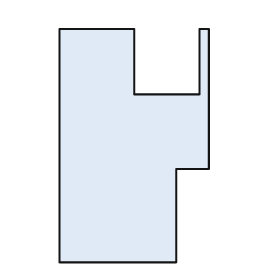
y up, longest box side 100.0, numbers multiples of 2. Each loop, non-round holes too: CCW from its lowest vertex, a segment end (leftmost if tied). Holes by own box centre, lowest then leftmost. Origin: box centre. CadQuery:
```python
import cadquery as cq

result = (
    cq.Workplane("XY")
    .moveTo(-32.0, -50.0)
    .lineTo(18.0, -50.0)
    .lineTo(18.0, -10.0)
    .lineTo(32.0, -10.0)
    .lineTo(32.0, 50.0)
    .lineTo(28.0, 50.0)
    .lineTo(28.0, 22.0)
    .lineTo(0.0, 22.0)
    .lineTo(0.0, 50.0)
    .lineTo(-32.0, 50.0)
    .close()
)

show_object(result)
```